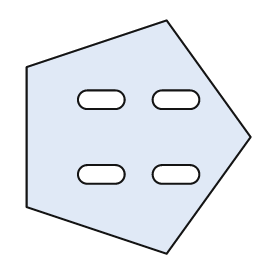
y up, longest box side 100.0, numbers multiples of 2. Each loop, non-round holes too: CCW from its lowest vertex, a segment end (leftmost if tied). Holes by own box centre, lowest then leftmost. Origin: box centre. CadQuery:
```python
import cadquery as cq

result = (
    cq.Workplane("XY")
    .moveTo(12.0, -50.0)
    .lineTo(48.0, 0.0)
    .lineTo(12.0, 50.0)
    .lineTo(-48.0, 30.0)
    .lineTo(-48.0, -30.0)
    .close()
    .moveTo(-22.0, -20.0)
    .lineTo(-10.0, -20.0)
    .threePointArc((-6.0, -16.0), (-10.0, -12.0))
    .lineTo(-22.0, -12.0)
    .threePointArc((-26.0, -16.0), (-22.0, -20.0))
    .close()
    .moveTo(10.0, -20.0)
    .lineTo(22.0, -20.0)
    .threePointArc((26.0, -16.0), (22.0, -12.0))
    .lineTo(10.0, -12.0)
    .threePointArc((6.0, -16.0), (10.0, -20.0))
    .close()
    .moveTo(-22.0, 12.0)
    .lineTo(-10.0, 12.0)
    .threePointArc((-6.0, 16.0), (-10.0, 20.0))
    .lineTo(-22.0, 20.0)
    .threePointArc((-26.0, 16.0), (-22.0, 12.0))
    .close()
    .moveTo(10.0, 12.0)
    .lineTo(22.0, 12.0)
    .threePointArc((26.0, 16.0), (22.0, 20.0))
    .lineTo(10.0, 20.0)
    .threePointArc((6.0, 16.0), (10.0, 12.0))
    .close()
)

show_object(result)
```